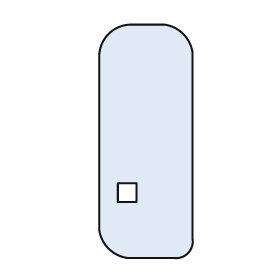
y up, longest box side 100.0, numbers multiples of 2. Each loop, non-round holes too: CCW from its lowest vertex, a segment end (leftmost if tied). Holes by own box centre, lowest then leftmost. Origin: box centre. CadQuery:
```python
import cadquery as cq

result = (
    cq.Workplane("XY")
    .moveTo(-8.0, -50.0)
    .lineTo(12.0, -50.0)
    .threePointArc((18.0, -48.0), (20.0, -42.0))
    .lineTo(20.0, 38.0)
    .threePointArc((16.0, 46.0), (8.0, 50.0))
    .lineTo(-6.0, 50.0)
    .threePointArc((-16.0, 46.0), (-20.0, 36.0))
    .lineTo(-20.0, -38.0)
    .threePointArc((-16.0, -46.0), (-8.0, -50.0))
    .close()
    .moveTo(-12.0, -26.0)
    .lineTo(-4.0, -26.0)
    .lineTo(-4.0, -18.0)
    .lineTo(-12.0, -18.0)
    .close()
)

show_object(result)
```